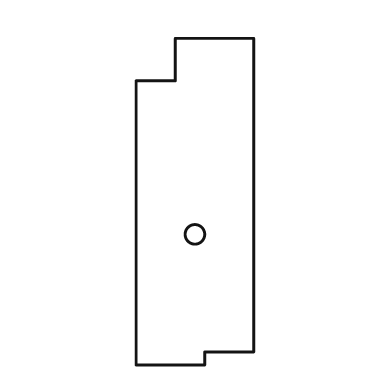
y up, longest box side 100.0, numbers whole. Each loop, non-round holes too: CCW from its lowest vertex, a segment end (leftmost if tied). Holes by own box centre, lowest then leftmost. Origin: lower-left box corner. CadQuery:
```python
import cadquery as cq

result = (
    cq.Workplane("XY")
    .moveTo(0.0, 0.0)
    .lineTo(21.0, 0.0)
    .lineTo(21.0, 4.0)
    .lineTo(36.0, 4.0)
    .lineTo(36.0, 100.0)
    .lineTo(12.0, 100.0)
    .lineTo(12.0, 87.0)
    .lineTo(0.0, 87.0)
    .close()
    .moveTo(18.0, 40.0)
    .circle(3.0)
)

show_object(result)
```